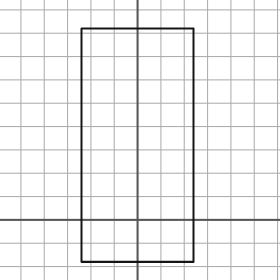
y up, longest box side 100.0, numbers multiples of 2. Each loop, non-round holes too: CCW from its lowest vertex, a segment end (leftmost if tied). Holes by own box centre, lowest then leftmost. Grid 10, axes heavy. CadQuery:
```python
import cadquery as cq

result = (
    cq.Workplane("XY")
    .moveTo(-24.0, -18.0)
    .lineTo(24.0, -18.0)
    .lineTo(24.0, 82.0)
    .lineTo(-24.0, 82.0)
    .close()
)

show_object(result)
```